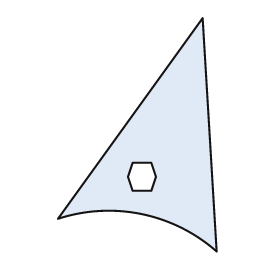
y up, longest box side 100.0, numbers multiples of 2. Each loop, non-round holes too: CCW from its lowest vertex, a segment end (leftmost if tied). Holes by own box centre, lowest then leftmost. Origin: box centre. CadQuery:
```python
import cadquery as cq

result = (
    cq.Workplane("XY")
    .moveTo(34.0, -50.0)
    .lineTo(28.0, 50.0)
    .lineTo(-34.0, -36.0)
    .threePointArc((2.0, -34.0), (34.0, -50.0))
    .close()
    .moveTo(-2.0, -24.0)
    .lineTo(6.0, -24.0)
    .lineTo(8.0, -18.0)
    .lineTo(6.0, -12.0)
    .lineTo(-2.0, -12.0)
    .lineTo(-4.0, -18.0)
    .close()
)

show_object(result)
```